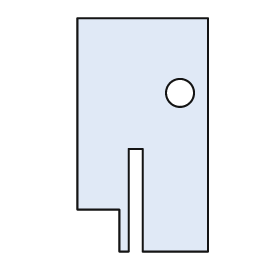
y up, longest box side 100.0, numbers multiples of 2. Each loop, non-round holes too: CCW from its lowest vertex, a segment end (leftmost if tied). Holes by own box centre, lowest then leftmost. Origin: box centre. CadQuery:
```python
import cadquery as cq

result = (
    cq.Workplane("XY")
    .moveTo(-10.0, -50.0)
    .lineTo(-6.0, -50.0)
    .lineTo(-6.0, -6.0)
    .lineTo(0.0, -6.0)
    .lineTo(0.0, -50.0)
    .lineTo(28.0, -50.0)
    .lineTo(28.0, 50.0)
    .lineTo(-28.0, 50.0)
    .lineTo(-28.0, -32.0)
    .lineTo(-10.0, -32.0)
    .close()
    .moveTo(16.0, 18.0)
    .circle(6.0)
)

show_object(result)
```